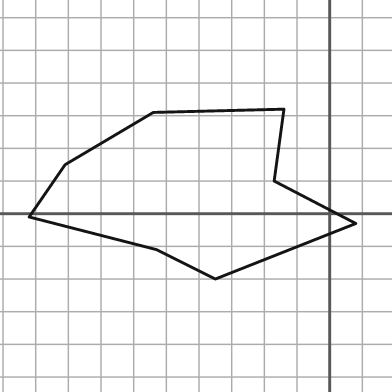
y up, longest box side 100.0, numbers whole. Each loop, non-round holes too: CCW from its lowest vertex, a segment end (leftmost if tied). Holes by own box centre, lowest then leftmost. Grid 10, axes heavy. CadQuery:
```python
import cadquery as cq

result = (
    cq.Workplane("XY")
    .moveTo(-35.0, -20.0)
    .lineTo(8.0, -3.0)
    .lineTo(-17.0, 10.0)
    .lineTo(-14.0, 32.0)
    .lineTo(-54.0, 31.0)
    .lineTo(-81.0, 15.0)
    .lineTo(-92.0, -1.0)
    .lineTo(-53.0, -11.0)
    .close()
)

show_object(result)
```